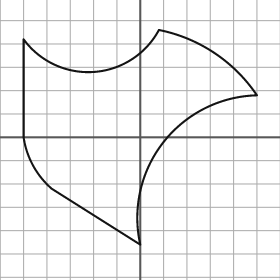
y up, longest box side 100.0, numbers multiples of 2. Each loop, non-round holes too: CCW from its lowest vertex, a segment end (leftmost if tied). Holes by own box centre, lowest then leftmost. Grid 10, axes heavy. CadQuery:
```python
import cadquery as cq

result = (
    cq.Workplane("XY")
    .moveTo(0.0, -46.0)
    .threePointArc((10.0, -2.0), (50.0, 18.0))
    .threePointArc((32.0, 36.0), (8.0, 46.0))
    .threePointArc((-20.0, 28.0), (-50.0, 42.0))
    .lineTo(-50.0, 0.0)
    .threePointArc((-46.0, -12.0), (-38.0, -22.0))
    .close()
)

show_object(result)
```